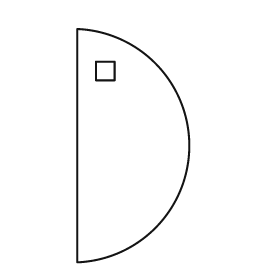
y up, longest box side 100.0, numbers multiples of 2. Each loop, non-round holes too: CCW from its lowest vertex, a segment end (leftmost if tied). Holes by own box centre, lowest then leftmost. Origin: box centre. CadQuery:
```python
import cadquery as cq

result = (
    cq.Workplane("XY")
    .moveTo(-24.0, -50.0)
    .threePointArc((24.0, 0.0), (-24.0, 50.0))
    .close()
    .moveTo(-16.0, 28.0)
    .lineTo(-8.0, 28.0)
    .lineTo(-8.0, 36.0)
    .lineTo(-16.0, 36.0)
    .close()
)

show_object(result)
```